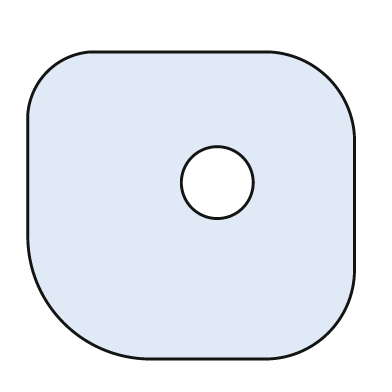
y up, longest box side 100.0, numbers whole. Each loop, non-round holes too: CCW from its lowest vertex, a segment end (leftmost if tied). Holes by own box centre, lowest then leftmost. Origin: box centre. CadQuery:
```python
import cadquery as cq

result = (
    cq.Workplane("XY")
    .moveTo(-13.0, -47.0)
    .lineTo(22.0, -47.0)
    .threePointArc((42.0, -39.0), (50.0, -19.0))
    .lineTo(50.0, 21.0)
    .threePointArc((42.0, 39.0), (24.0, 47.0))
    .lineTo(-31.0, 47.0)
    .threePointArc((-44.0, 41.0), (-50.0, 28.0))
    .lineTo(-50.0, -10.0)
    .threePointArc((-39.0, -36.0), (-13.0, -47.0))
    .close()
    .moveTo(8.0, 7.0)
    .circle(11.0)
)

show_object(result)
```